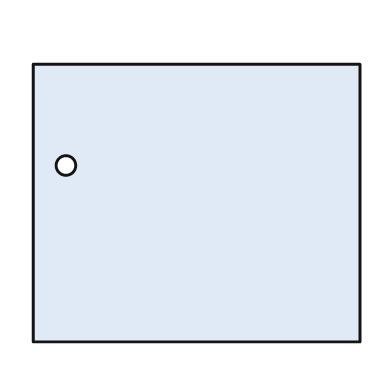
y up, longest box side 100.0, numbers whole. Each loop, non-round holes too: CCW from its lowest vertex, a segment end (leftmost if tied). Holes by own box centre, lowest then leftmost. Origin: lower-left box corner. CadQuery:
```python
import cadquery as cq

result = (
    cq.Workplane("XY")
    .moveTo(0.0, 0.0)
    .lineTo(100.0, 0.0)
    .lineTo(100.0, 85.0)
    .lineTo(0.0, 85.0)
    .close()
    .moveTo(10.0, 54.0)
    .circle(3.0)
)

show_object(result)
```